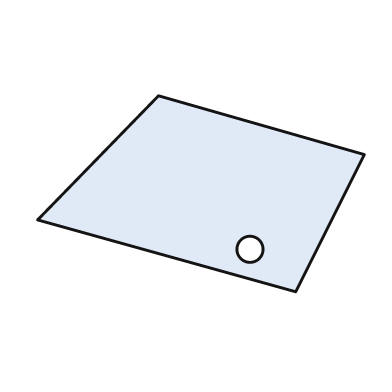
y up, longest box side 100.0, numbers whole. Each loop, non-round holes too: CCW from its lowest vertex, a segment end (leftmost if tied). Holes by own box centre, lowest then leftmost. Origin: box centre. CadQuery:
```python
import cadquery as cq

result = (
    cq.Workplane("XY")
    .moveTo(29.0, -30.0)
    .lineTo(50.0, 12.0)
    .lineTo(-13.0, 30.0)
    .lineTo(-50.0, -8.0)
    .close()
    .moveTo(15.0, -17.0)
    .circle(4.0)
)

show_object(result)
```